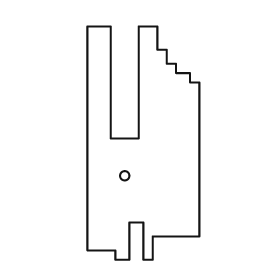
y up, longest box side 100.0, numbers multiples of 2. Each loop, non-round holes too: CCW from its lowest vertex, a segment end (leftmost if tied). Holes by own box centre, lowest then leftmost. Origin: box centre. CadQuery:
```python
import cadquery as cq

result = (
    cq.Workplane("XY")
    .moveTo(-12.0, -50.0)
    .lineTo(-6.0, -50.0)
    .lineTo(-6.0, -34.0)
    .lineTo(0.0, -34.0)
    .lineTo(0.0, -50.0)
    .lineTo(4.0, -50.0)
    .lineTo(4.0, -40.0)
    .lineTo(24.0, -40.0)
    .lineTo(24.0, 26.0)
    .lineTo(20.0, 26.0)
    .lineTo(20.0, 30.0)
    .lineTo(14.0, 30.0)
    .lineTo(14.0, 34.0)
    .lineTo(10.0, 34.0)
    .lineTo(10.0, 40.0)
    .lineTo(6.0, 40.0)
    .lineTo(6.0, 50.0)
    .lineTo(-2.0, 50.0)
    .lineTo(-2.0, 2.0)
    .lineTo(-14.0, 2.0)
    .lineTo(-14.0, 50.0)
    .lineTo(-24.0, 50.0)
    .lineTo(-24.0, -46.0)
    .lineTo(-12.0, -46.0)
    .close()
    .moveTo(-8.0, -14.0)
    .circle(2.0)
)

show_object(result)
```